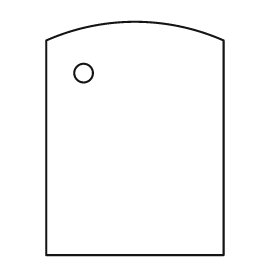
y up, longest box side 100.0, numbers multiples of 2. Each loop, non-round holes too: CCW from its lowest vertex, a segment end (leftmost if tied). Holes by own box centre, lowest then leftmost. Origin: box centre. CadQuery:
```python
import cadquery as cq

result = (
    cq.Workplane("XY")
    .moveTo(-38.0, -50.0)
    .lineTo(38.0, -50.0)
    .lineTo(38.0, 42.0)
    .threePointArc((0.0, 50.0), (-38.0, 42.0))
    .close()
    .moveTo(-22.0, 28.0)
    .circle(4.0)
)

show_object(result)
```